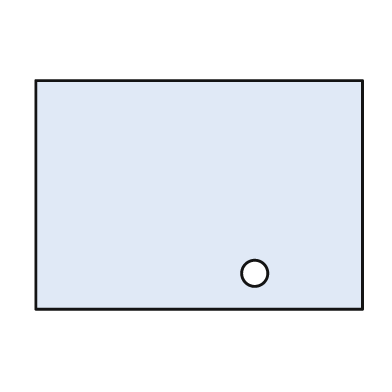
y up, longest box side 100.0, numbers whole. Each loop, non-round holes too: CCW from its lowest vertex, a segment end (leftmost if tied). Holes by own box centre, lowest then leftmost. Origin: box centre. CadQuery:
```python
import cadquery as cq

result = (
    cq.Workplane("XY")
    .moveTo(-50.0, -35.0)
    .lineTo(50.0, -35.0)
    .lineTo(50.0, 35.0)
    .lineTo(-50.0, 35.0)
    .close()
    .moveTo(17.0, -24.0)
    .circle(4.0)
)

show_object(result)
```